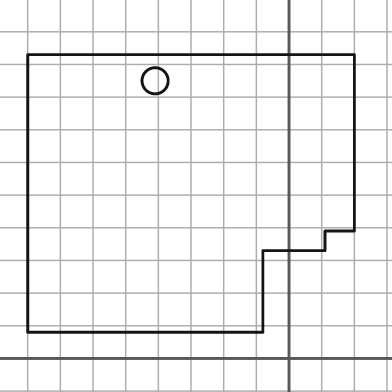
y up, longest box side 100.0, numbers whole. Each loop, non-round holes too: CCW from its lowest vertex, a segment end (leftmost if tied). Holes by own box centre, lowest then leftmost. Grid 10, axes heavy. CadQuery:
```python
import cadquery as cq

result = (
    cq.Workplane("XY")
    .moveTo(-80.0, 8.0)
    .lineTo(-8.0, 8.0)
    .lineTo(-8.0, 33.0)
    .lineTo(11.0, 33.0)
    .lineTo(11.0, 39.0)
    .lineTo(20.0, 39.0)
    .lineTo(20.0, 93.0)
    .lineTo(-80.0, 93.0)
    .close()
    .moveTo(-41.0, 85.0)
    .circle(4.0)
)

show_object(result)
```